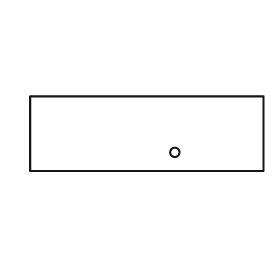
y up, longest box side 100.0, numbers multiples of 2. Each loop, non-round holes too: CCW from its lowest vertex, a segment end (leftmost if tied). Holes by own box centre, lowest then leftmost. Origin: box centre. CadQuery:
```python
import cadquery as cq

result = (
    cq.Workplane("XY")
    .moveTo(-50.0, -16.0)
    .lineTo(50.0, -16.0)
    .lineTo(50.0, 16.0)
    .lineTo(-50.0, 16.0)
    .close()
    .moveTo(12.0, -8.0)
    .circle(2.0)
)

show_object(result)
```